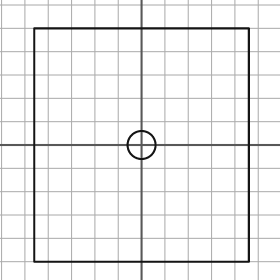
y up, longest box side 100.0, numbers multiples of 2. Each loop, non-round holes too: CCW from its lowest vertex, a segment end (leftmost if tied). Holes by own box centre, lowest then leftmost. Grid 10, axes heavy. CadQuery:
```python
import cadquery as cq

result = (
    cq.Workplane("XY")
    .moveTo(-46.0, -50.0)
    .lineTo(46.0, -50.0)
    .lineTo(46.0, 50.0)
    .lineTo(-46.0, 50.0)
    .close()
    .moveTo(0.0, 0.0)
    .circle(6.0)
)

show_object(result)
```